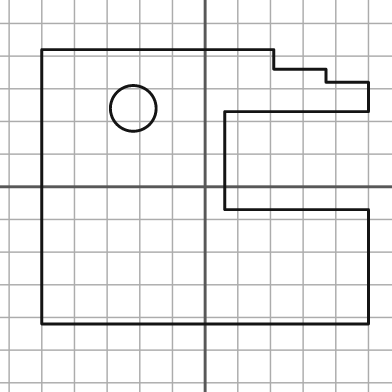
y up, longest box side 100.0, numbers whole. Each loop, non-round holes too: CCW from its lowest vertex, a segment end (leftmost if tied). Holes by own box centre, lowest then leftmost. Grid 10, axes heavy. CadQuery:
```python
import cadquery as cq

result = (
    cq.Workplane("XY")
    .moveTo(-50.0, -42.0)
    .lineTo(50.0, -42.0)
    .lineTo(50.0, -7.0)
    .lineTo(6.0, -7.0)
    .lineTo(6.0, 23.0)
    .lineTo(50.0, 23.0)
    .lineTo(50.0, 32.0)
    .lineTo(37.0, 32.0)
    .lineTo(37.0, 36.0)
    .lineTo(21.0, 36.0)
    .lineTo(21.0, 42.0)
    .lineTo(-50.0, 42.0)
    .close()
    .moveTo(-22.0, 24.0)
    .circle(7.0)
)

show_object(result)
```